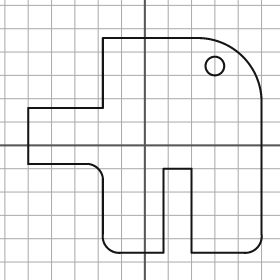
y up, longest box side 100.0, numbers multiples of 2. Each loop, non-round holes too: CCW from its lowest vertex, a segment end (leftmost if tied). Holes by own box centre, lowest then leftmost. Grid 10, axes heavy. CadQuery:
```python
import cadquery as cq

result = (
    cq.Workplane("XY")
    .moveTo(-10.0, -46.0)
    .lineTo(8.0, -46.0)
    .lineTo(8.0, -10.0)
    .lineTo(20.0, -10.0)
    .lineTo(20.0, -46.0)
    .lineTo(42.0, -46.0)
    .threePointArc((48.0, -44.0), (50.0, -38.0))
    .lineTo(50.0, 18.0)
    .threePointArc((42.0, 38.0), (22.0, 46.0))
    .lineTo(-18.0, 46.0)
    .lineTo(-18.0, 16.0)
    .lineTo(-50.0, 16.0)
    .lineTo(-50.0, -8.0)
    .lineTo(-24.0, -8.0)
    .threePointArc((-20.0, -10.0), (-18.0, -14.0))
    .lineTo(-18.0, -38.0)
    .threePointArc((-16.0, -44.0), (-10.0, -46.0))
    .close()
    .moveTo(30.0, 34.0)
    .circle(4.0)
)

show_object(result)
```